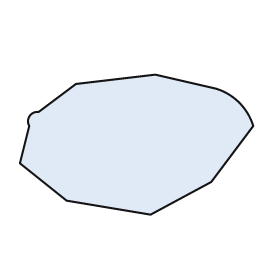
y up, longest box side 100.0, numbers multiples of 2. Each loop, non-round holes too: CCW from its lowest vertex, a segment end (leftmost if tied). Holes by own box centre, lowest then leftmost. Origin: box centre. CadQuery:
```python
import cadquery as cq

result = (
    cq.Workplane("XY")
    .moveTo(6.0, -30.0)
    .lineTo(32.0, -16.0)
    .lineTo(50.0, 8.0)
    .threePointArc((44.0, 18.0), (34.0, 24.0))
    .lineTo(8.0, 30.0)
    .lineTo(-26.0, 26.0)
    .lineTo(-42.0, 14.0)
    .threePointArc((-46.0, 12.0), (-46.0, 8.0))
    .lineTo(-50.0, -8.0)
    .lineTo(-30.0, -24.0)
    .close()
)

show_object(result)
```